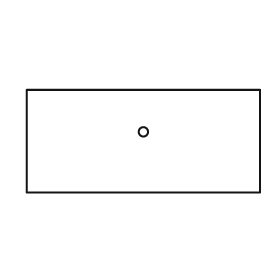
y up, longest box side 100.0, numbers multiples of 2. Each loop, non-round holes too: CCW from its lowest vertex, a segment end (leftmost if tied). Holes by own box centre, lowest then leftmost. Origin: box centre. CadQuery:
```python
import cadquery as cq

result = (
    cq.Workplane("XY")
    .moveTo(-50.0, -22.0)
    .lineTo(50.0, -22.0)
    .lineTo(50.0, 22.0)
    .lineTo(-50.0, 22.0)
    .close()
    .moveTo(0.0, 4.0)
    .circle(2.0)
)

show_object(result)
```